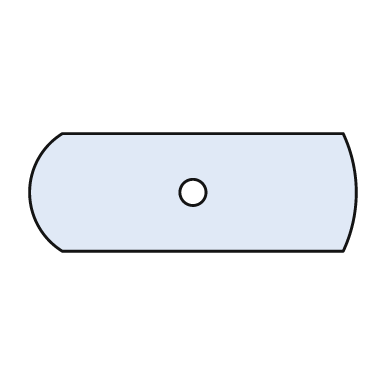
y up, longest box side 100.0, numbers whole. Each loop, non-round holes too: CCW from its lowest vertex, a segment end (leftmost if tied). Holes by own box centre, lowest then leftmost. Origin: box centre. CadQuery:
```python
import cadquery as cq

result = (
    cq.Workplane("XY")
    .moveTo(-40.0, -18.0)
    .lineTo(46.0, -18.0)
    .threePointArc((50.0, 0.0), (46.0, 18.0))
    .lineTo(-40.0, 18.0)
    .threePointArc((-50.0, 0.0), (-40.0, -18.0))
    .close()
    .moveTo(0.0, 0.0)
    .circle(4.0)
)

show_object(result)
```